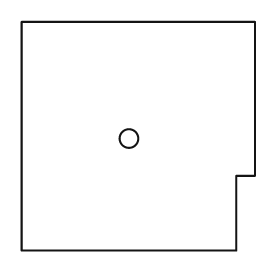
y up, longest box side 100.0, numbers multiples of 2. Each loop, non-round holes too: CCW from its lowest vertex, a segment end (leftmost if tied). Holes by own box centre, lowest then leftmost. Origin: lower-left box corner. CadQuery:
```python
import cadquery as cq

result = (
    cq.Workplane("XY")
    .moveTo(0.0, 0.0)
    .lineTo(92.0, 0.0)
    .lineTo(92.0, 32.0)
    .lineTo(100.0, 32.0)
    .lineTo(100.0, 98.0)
    .lineTo(0.0, 98.0)
    .close()
    .moveTo(46.0, 48.0)
    .circle(4.0)
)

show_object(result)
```